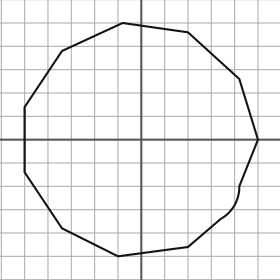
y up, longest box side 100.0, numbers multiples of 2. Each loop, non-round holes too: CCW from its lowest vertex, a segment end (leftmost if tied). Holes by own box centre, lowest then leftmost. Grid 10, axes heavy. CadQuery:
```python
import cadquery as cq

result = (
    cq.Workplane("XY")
    .moveTo(-10.0, -50.0)
    .lineTo(20.0, -46.0)
    .lineTo(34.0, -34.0)
    .threePointArc((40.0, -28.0), (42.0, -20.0))
    .lineTo(50.0, 0.0)
    .lineTo(42.0, 26.0)
    .lineTo(20.0, 46.0)
    .lineTo(-8.0, 50.0)
    .lineTo(-34.0, 38.0)
    .lineTo(-50.0, 14.0)
    .lineTo(-50.0, -14.0)
    .lineTo(-34.0, -38.0)
    .close()
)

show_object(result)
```